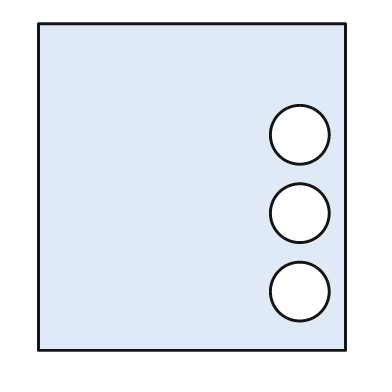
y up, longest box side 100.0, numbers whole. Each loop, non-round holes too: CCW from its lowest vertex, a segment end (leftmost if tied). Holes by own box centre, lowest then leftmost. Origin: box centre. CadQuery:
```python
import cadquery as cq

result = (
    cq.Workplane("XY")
    .moveTo(-47.0, -50.0)
    .lineTo(47.0, -50.0)
    .lineTo(47.0, 50.0)
    .lineTo(-47.0, 50.0)
    .close()
    .moveTo(33.0, -32.0)
    .circle(9.0)
    .moveTo(33.0, -8.0)
    .circle(9.0)
    .moveTo(33.0, 16.0)
    .circle(9.0)
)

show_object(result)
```